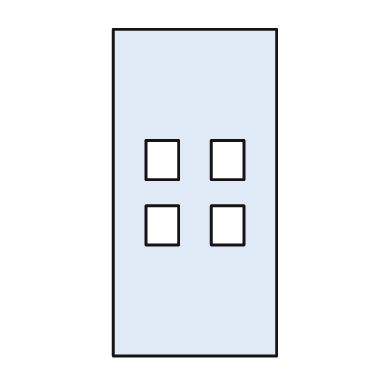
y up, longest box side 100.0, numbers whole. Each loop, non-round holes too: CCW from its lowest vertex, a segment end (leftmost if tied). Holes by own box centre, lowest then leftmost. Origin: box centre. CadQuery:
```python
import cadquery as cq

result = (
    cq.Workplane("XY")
    .moveTo(-25.0, -50.0)
    .lineTo(25.0, -50.0)
    .lineTo(25.0, 50.0)
    .lineTo(-25.0, 50.0)
    .close()
    .moveTo(-15.0, -16.0)
    .lineTo(-5.0, -16.0)
    .lineTo(-5.0, -4.0)
    .lineTo(-15.0, -4.0)
    .close()
    .moveTo(5.0, -16.0)
    .lineTo(15.0, -16.0)
    .lineTo(15.0, -4.0)
    .lineTo(5.0, -4.0)
    .close()
    .moveTo(-15.0, 4.0)
    .lineTo(-5.0, 4.0)
    .lineTo(-5.0, 16.0)
    .lineTo(-15.0, 16.0)
    .close()
    .moveTo(5.0, 4.0)
    .lineTo(15.0, 4.0)
    .lineTo(15.0, 16.0)
    .lineTo(5.0, 16.0)
    .close()
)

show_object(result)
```